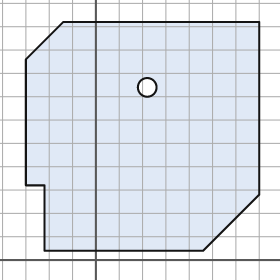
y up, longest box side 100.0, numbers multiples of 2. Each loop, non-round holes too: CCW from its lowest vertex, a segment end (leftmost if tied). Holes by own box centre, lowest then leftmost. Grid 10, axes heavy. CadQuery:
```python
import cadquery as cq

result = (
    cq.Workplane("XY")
    .moveTo(-22.0, 4.0)
    .lineTo(46.0, 4.0)
    .lineTo(70.0, 28.0)
    .lineTo(70.0, 102.0)
    .lineTo(-14.0, 102.0)
    .lineTo(-30.0, 86.0)
    .lineTo(-30.0, 32.0)
    .lineTo(-22.0, 32.0)
    .close()
    .moveTo(22.0, 74.0)
    .circle(4.0)
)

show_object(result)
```